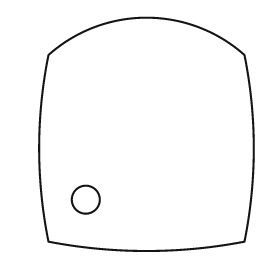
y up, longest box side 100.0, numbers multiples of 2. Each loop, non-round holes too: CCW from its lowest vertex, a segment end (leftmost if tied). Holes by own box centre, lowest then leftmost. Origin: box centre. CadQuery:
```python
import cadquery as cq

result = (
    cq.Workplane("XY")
    .moveTo(-42.0, -46.0)
    .threePointArc((0.0, -50.0), (42.0, -46.0))
    .threePointArc((46.0, -6.0), (42.0, 34.0))
    .threePointArc((0.0, 50.0), (-42.0, 34.0))
    .threePointArc((-46.0, -6.0), (-42.0, -46.0))
    .close()
    .moveTo(-26.0, -28.0)
    .circle(6.0)
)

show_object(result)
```